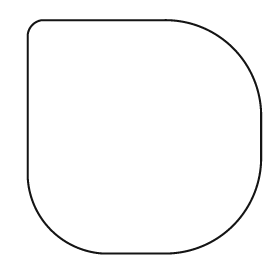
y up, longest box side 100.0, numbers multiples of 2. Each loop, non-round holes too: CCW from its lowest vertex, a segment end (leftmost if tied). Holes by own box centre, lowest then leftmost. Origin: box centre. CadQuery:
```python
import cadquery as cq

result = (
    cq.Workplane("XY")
    .moveTo(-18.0, -50.0)
    .lineTo(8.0, -50.0)
    .threePointArc((38.0, -38.0), (50.0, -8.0))
    .lineTo(50.0, 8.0)
    .threePointArc((38.0, 38.0), (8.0, 50.0))
    .lineTo(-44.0, 50.0)
    .threePointArc((-48.0, 48.0), (-50.0, 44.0))
    .lineTo(-50.0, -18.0)
    .threePointArc((-40.0, -40.0), (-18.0, -50.0))
    .close()
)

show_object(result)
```